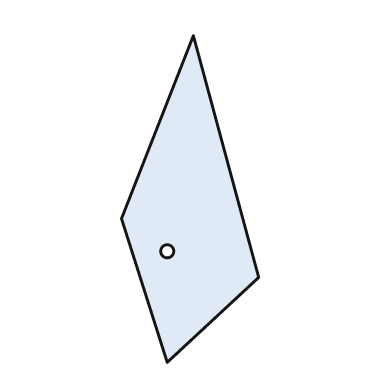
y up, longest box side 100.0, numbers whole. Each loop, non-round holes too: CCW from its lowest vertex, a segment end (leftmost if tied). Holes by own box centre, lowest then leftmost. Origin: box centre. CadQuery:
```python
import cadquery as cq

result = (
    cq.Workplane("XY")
    .moveTo(-7.0, -50.0)
    .lineTo(21.0, -24.0)
    .lineTo(1.0, 50.0)
    .lineTo(-21.0, -6.0)
    .close()
    .moveTo(-7.0, -16.0)
    .circle(2.0)
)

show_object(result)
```